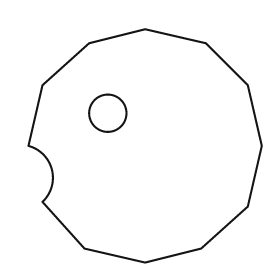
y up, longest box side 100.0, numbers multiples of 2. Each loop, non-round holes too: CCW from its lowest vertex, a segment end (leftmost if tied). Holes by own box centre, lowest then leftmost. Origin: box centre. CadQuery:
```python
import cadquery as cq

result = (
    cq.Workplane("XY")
    .moveTo(0.0, -50.0)
    .lineTo(24.0, -44.0)
    .lineTo(44.0, -26.0)
    .lineTo(50.0, 0.0)
    .lineTo(44.0, 26.0)
    .lineTo(26.0, 44.0)
    .lineTo(0.0, 50.0)
    .lineTo(-24.0, 44.0)
    .lineTo(-44.0, 26.0)
    .lineTo(-50.0, 0.0)
    .threePointArc((-40.0, -10.0), (-44.0, -24.0))
    .lineTo(-26.0, -44.0)
    .close()
    .moveTo(-16.0, 14.0)
    .circle(8.0)
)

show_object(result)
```